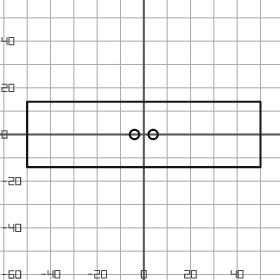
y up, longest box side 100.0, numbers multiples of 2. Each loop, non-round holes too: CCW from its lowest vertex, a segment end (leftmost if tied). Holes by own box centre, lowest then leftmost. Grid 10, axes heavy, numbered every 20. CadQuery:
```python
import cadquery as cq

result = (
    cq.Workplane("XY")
    .moveTo(-50.0, -14.0)
    .lineTo(50.0, -14.0)
    .lineTo(50.0, 14.0)
    .lineTo(-50.0, 14.0)
    .close()
    .moveTo(-4.0, 0.0)
    .circle(2.0)
    .moveTo(4.0, 0.0)
    .circle(2.0)
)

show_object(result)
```